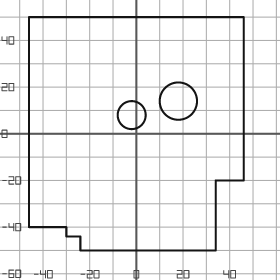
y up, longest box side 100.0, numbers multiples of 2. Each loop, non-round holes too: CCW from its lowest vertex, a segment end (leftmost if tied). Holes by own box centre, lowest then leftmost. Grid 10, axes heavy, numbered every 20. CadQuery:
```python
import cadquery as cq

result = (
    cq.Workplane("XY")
    .moveTo(-24.0, -50.0)
    .lineTo(34.0, -50.0)
    .lineTo(34.0, -20.0)
    .lineTo(46.0, -20.0)
    .lineTo(46.0, 50.0)
    .lineTo(-46.0, 50.0)
    .lineTo(-46.0, -40.0)
    .lineTo(-30.0, -40.0)
    .lineTo(-30.0, -44.0)
    .lineTo(-24.0, -44.0)
    .close()
    .moveTo(-2.0, 8.0)
    .circle(6.0)
    .moveTo(18.0, 14.0)
    .circle(8.0)
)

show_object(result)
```